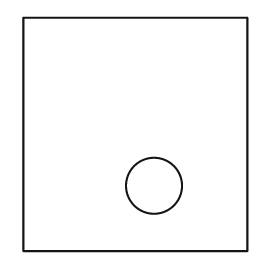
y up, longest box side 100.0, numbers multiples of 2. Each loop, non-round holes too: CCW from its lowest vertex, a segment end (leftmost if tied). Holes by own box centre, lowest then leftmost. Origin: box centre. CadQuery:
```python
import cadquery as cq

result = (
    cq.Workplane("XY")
    .moveTo(-48.0, -50.0)
    .lineTo(48.0, -50.0)
    .lineTo(48.0, 50.0)
    .lineTo(-48.0, 50.0)
    .close()
    .moveTo(8.0, -22.0)
    .circle(12.0)
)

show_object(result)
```